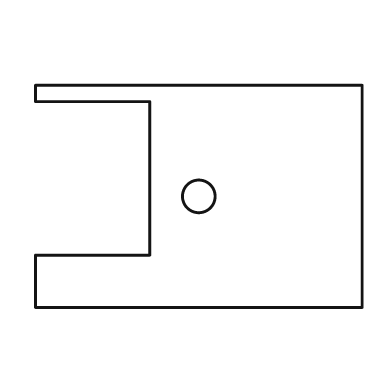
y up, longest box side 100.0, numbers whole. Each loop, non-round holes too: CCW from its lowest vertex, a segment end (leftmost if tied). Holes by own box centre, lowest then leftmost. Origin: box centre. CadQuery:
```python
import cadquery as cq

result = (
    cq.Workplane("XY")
    .moveTo(-50.0, -34.0)
    .lineTo(50.0, -34.0)
    .lineTo(50.0, 34.0)
    .lineTo(-50.0, 34.0)
    .lineTo(-50.0, 29.0)
    .lineTo(-15.0, 29.0)
    .lineTo(-15.0, -18.0)
    .lineTo(-50.0, -18.0)
    .close()
    .moveTo(0.0, 0.0)
    .circle(5.0)
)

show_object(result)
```